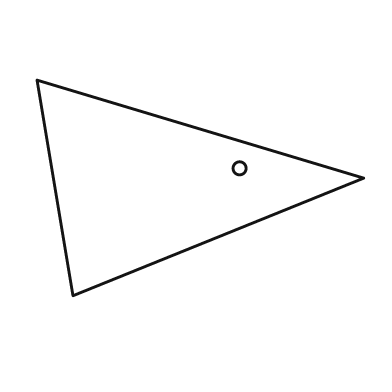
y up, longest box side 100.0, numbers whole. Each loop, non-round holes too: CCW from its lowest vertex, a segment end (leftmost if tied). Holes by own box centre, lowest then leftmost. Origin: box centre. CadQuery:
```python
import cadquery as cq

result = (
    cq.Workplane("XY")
    .moveTo(-39.0, -33.0)
    .lineTo(50.0, 3.0)
    .lineTo(-50.0, 33.0)
    .close()
    .moveTo(12.0, 6.0)
    .circle(2.0)
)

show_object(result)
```